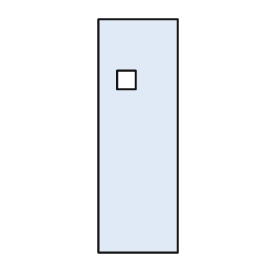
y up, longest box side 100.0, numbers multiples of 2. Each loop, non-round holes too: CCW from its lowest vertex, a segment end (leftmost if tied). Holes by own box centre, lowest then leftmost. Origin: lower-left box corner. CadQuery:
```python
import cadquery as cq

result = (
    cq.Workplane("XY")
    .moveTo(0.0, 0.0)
    .lineTo(34.0, 0.0)
    .lineTo(34.0, 100.0)
    .lineTo(0.0, 100.0)
    .close()
    .moveTo(8.0, 70.0)
    .lineTo(16.0, 70.0)
    .lineTo(16.0, 78.0)
    .lineTo(8.0, 78.0)
    .close()
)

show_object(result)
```